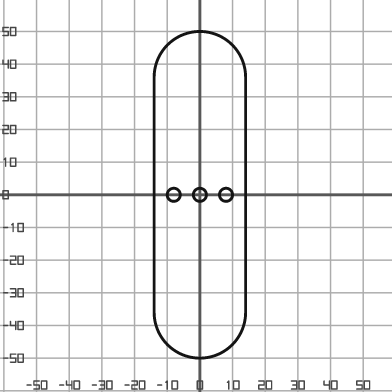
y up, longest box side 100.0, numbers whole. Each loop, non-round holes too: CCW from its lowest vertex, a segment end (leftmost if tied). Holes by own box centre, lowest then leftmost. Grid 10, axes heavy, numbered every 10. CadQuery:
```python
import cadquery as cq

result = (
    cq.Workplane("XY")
    .moveTo(-14.0, -36.0)
    .threePointArc((0.0, -50.0), (14.0, -36.0))
    .lineTo(14.0, 36.0)
    .threePointArc((0.0, 50.0), (-14.0, 36.0))
    .close()
    .moveTo(-8.0, 0.0)
    .circle(2.0)
    .moveTo(0.0, 0.0)
    .circle(2.0)
    .moveTo(8.0, 0.0)
    .circle(2.0)
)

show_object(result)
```